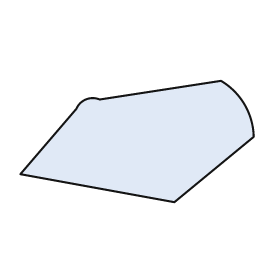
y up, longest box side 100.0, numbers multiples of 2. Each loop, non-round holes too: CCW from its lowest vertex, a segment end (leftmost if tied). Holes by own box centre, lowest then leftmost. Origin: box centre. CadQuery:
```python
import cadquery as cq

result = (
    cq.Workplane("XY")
    .moveTo(16.0, -26.0)
    .lineTo(50.0, 2.0)
    .threePointArc((46.0, 16.0), (36.0, 26.0))
    .lineTo(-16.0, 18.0)
    .threePointArc((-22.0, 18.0), (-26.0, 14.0))
    .lineTo(-50.0, -14.0)
    .close()
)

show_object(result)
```